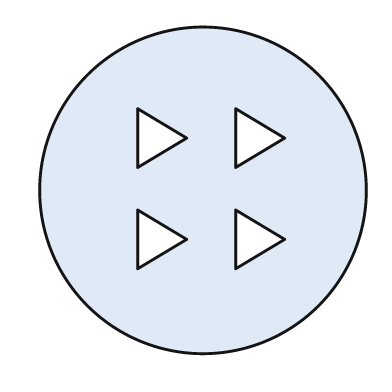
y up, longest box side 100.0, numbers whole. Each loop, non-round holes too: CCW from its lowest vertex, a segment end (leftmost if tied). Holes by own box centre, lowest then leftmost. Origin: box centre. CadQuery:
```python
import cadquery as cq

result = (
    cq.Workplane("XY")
    .moveTo(0.0, 0.0)
    .circle(50.0)
    .moveTo(-20.0, -24.0)
    .lineTo(-5.0, -15.0)
    .lineTo(-20.0, -6.0)
    .close()
    .moveTo(10.0, -24.0)
    .lineTo(25.0, -15.0)
    .lineTo(10.0, -6.0)
    .close()
    .moveTo(-20.0, 7.0)
    .lineTo(-5.0, 16.0)
    .lineTo(-20.0, 25.0)
    .close()
    .moveTo(10.0, 7.0)
    .lineTo(25.0, 16.0)
    .lineTo(10.0, 25.0)
    .close()
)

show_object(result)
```